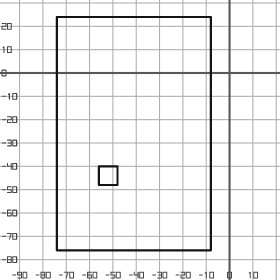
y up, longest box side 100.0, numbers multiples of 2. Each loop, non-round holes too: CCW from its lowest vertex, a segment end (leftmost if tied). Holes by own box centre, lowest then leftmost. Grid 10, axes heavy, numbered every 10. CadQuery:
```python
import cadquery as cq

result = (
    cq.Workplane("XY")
    .moveTo(-74.0, -76.0)
    .lineTo(-8.0, -76.0)
    .lineTo(-8.0, 24.0)
    .lineTo(-74.0, 24.0)
    .close()
    .moveTo(-56.0, -48.0)
    .lineTo(-48.0, -48.0)
    .lineTo(-48.0, -40.0)
    .lineTo(-56.0, -40.0)
    .close()
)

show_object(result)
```